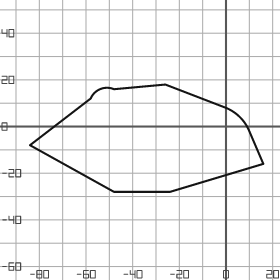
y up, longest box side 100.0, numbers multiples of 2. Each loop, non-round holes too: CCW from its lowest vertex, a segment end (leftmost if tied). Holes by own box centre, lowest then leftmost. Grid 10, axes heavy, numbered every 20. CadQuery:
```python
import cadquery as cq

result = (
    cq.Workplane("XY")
    .moveTo(-48.0, -28.0)
    .lineTo(-24.0, -28.0)
    .lineTo(16.0, -16.0)
    .lineTo(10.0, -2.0)
    .threePointArc((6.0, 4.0), (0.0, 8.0))
    .lineTo(-26.0, 18.0)
    .lineTo(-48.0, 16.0)
    .threePointArc((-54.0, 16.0), (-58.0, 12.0))
    .lineTo(-84.0, -8.0)
    .close()
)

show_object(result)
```